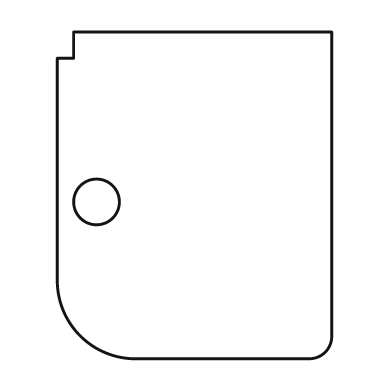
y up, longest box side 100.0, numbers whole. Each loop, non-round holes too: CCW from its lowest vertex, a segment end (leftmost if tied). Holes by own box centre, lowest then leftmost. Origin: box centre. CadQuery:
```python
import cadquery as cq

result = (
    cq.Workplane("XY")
    .moveTo(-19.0, -50.0)
    .lineTo(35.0, -50.0)
    .threePointArc((40.0, -48.0), (42.0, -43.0))
    .lineTo(42.0, 50.0)
    .lineTo(-37.0, 50.0)
    .lineTo(-37.0, 42.0)
    .lineTo(-42.0, 42.0)
    .lineTo(-42.0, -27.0)
    .threePointArc((-35.0, -43.0), (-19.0, -50.0))
    .close()
    .moveTo(-30.0, -2.0)
    .circle(7.0)
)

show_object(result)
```